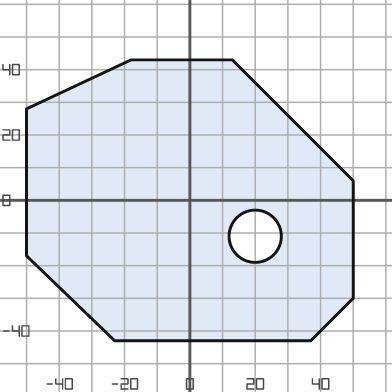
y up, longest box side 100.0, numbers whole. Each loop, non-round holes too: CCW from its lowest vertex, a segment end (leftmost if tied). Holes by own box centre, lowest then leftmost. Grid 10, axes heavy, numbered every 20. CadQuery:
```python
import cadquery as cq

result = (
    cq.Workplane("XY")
    .moveTo(-23.0, -43.0)
    .lineTo(37.0, -43.0)
    .lineTo(50.0, -30.0)
    .lineTo(50.0, 6.0)
    .lineTo(13.0, 43.0)
    .lineTo(-18.0, 43.0)
    .lineTo(-50.0, 28.0)
    .lineTo(-50.0, -17.0)
    .close()
    .moveTo(20.0, -11.0)
    .circle(8.0)
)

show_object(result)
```